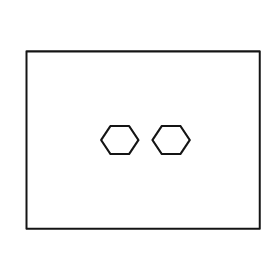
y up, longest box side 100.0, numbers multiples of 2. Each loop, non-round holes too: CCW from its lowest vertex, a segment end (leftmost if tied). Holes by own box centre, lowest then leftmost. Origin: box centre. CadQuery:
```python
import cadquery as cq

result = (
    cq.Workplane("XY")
    .moveTo(-50.0, -38.0)
    .lineTo(50.0, -38.0)
    .lineTo(50.0, 38.0)
    .lineTo(-50.0, 38.0)
    .close()
    .moveTo(-14.0, -6.0)
    .lineTo(-6.0, -6.0)
    .lineTo(-2.0, 0.0)
    .lineTo(-6.0, 6.0)
    .lineTo(-14.0, 6.0)
    .lineTo(-18.0, 0.0)
    .close()
    .moveTo(8.0, -6.0)
    .lineTo(16.0, -6.0)
    .lineTo(20.0, 0.0)
    .lineTo(16.0, 6.0)
    .lineTo(8.0, 6.0)
    .lineTo(4.0, 0.0)
    .close()
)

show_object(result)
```